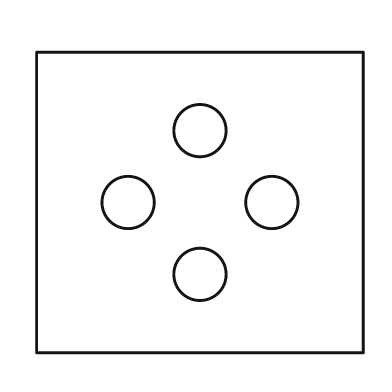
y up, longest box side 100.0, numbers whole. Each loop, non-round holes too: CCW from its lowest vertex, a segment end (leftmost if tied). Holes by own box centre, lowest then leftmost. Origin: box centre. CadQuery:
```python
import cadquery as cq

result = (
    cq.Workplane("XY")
    .moveTo(-50.0, -46.0)
    .lineTo(50.0, -46.0)
    .lineTo(50.0, 46.0)
    .lineTo(-50.0, 46.0)
    .close()
    .moveTo(0.0, -22.0)
    .circle(8.0)
    .moveTo(-22.0, 0.0)
    .circle(8.0)
    .moveTo(22.0, 0.0)
    .circle(8.0)
    .moveTo(0.0, 22.0)
    .circle(8.0)
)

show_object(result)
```